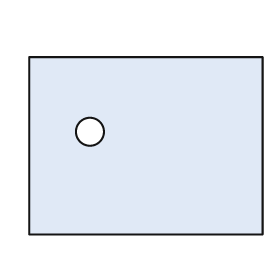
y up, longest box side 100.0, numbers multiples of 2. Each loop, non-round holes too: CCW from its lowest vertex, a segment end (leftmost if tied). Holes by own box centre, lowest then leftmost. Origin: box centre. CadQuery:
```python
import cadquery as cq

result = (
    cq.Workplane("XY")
    .moveTo(-50.0, -38.0)
    .lineTo(50.0, -38.0)
    .lineTo(50.0, 38.0)
    .lineTo(-50.0, 38.0)
    .close()
    .moveTo(-24.0, 6.0)
    .circle(6.0)
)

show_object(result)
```